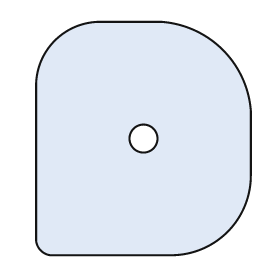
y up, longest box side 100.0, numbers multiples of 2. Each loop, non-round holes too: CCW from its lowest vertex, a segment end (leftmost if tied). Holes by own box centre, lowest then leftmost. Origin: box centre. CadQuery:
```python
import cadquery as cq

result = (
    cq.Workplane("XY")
    .moveTo(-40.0, -50.0)
    .lineTo(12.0, -50.0)
    .threePointArc((36.0, -40.0), (46.0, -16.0))
    .lineTo(46.0, 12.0)
    .threePointArc((34.0, 38.0), (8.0, 50.0))
    .lineTo(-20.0, 50.0)
    .threePointArc((-38.0, 42.0), (-46.0, 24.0))
    .lineTo(-46.0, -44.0)
    .threePointArc((-44.0, -48.0), (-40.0, -50.0))
    .close()
    .moveTo(0.0, 0.0)
    .circle(6.0)
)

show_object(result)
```